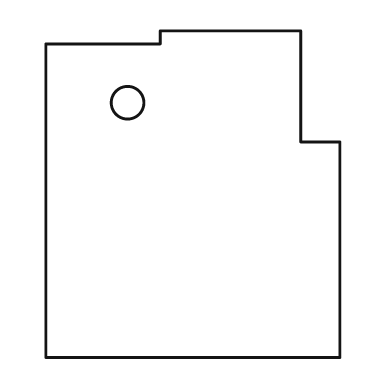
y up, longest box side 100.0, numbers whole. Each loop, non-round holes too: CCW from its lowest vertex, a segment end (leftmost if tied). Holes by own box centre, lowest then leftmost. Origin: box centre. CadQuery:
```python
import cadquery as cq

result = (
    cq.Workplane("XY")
    .moveTo(-45.0, -50.0)
    .lineTo(45.0, -50.0)
    .lineTo(45.0, 16.0)
    .lineTo(33.0, 16.0)
    .lineTo(33.0, 50.0)
    .lineTo(-10.0, 50.0)
    .lineTo(-10.0, 46.0)
    .lineTo(-45.0, 46.0)
    .close()
    .moveTo(-20.0, 28.0)
    .circle(5.0)
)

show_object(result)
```